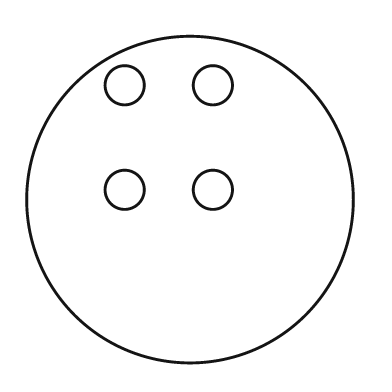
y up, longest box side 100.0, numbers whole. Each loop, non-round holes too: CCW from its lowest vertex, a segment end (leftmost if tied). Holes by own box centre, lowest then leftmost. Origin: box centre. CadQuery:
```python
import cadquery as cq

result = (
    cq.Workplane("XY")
    .moveTo(0.0, 0.0)
    .circle(50.0)
    .moveTo(-20.0, 3.0)
    .circle(6.0)
    .moveTo(7.0, 3.0)
    .circle(6.0)
    .moveTo(-20.0, 35.0)
    .circle(6.0)
    .moveTo(7.0, 35.0)
    .circle(6.0)
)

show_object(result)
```